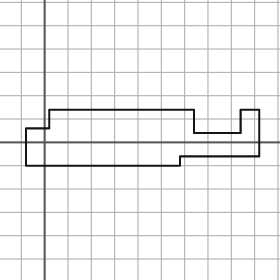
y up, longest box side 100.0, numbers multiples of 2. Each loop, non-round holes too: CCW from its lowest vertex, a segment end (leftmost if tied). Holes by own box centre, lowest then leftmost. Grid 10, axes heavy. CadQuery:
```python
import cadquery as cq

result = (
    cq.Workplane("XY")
    .moveTo(-8.0, -10.0)
    .lineTo(58.0, -10.0)
    .lineTo(58.0, -6.0)
    .lineTo(92.0, -6.0)
    .lineTo(92.0, 14.0)
    .lineTo(84.0, 14.0)
    .lineTo(84.0, 4.0)
    .lineTo(64.0, 4.0)
    .lineTo(64.0, 14.0)
    .lineTo(2.0, 14.0)
    .lineTo(2.0, 6.0)
    .lineTo(-8.0, 6.0)
    .close()
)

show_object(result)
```